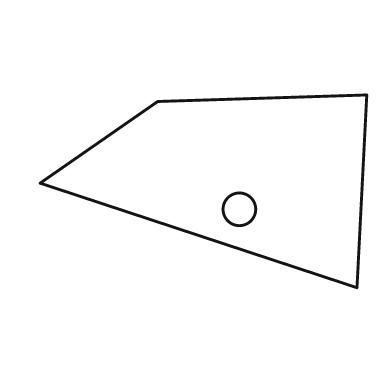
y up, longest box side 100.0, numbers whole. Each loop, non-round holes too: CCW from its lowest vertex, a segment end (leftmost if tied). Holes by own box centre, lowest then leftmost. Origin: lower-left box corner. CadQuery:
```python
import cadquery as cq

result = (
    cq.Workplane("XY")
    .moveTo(97.0, 0.0)
    .lineTo(100.0, 59.0)
    .lineTo(36.0, 57.0)
    .lineTo(0.0, 32.0)
    .close()
    .moveTo(61.0, 24.0)
    .circle(5.0)
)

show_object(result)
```